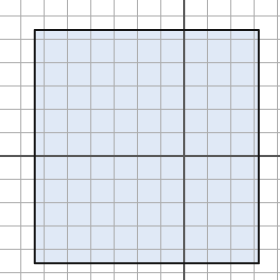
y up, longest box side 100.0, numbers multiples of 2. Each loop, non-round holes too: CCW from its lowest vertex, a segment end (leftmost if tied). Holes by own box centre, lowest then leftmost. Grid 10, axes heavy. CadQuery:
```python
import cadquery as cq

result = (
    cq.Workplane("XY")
    .moveTo(-64.0, -46.0)
    .lineTo(32.0, -46.0)
    .lineTo(32.0, 54.0)
    .lineTo(-64.0, 54.0)
    .close()
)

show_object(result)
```